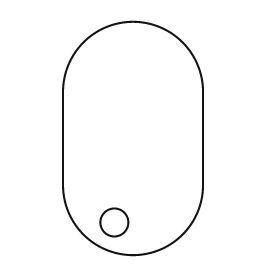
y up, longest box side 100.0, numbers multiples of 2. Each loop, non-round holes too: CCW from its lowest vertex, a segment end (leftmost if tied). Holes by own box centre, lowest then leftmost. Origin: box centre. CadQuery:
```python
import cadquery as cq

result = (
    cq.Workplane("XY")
    .moveTo(-30.0, -20.0)
    .threePointArc((0.0, -50.0), (30.0, -20.0))
    .lineTo(30.0, 20.0)
    .threePointArc((0.0, 50.0), (-30.0, 20.0))
    .close()
    .moveTo(-8.0, -36.0)
    .circle(6.0)
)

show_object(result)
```